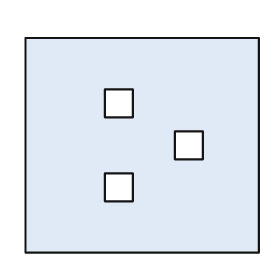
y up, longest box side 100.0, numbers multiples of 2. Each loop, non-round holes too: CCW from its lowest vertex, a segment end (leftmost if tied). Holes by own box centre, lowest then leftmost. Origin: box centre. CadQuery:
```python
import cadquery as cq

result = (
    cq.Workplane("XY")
    .moveTo(-50.0, -46.0)
    .lineTo(50.0, -46.0)
    .lineTo(50.0, 46.0)
    .lineTo(-50.0, 46.0)
    .close()
    .moveTo(-16.0, -24.0)
    .lineTo(-4.0, -24.0)
    .lineTo(-4.0, -12.0)
    .lineTo(-16.0, -12.0)
    .close()
    .moveTo(14.0, -6.0)
    .lineTo(26.0, -6.0)
    .lineTo(26.0, 6.0)
    .lineTo(14.0, 6.0)
    .close()
    .moveTo(-16.0, 12.0)
    .lineTo(-4.0, 12.0)
    .lineTo(-4.0, 24.0)
    .lineTo(-16.0, 24.0)
    .close()
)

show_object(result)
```